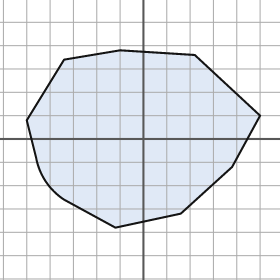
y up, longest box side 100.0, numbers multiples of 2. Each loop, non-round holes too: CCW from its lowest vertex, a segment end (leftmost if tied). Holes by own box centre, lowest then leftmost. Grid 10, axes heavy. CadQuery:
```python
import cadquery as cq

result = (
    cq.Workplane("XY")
    .moveTo(-12.0, -38.0)
    .lineTo(16.0, -32.0)
    .lineTo(38.0, -12.0)
    .lineTo(50.0, 10.0)
    .lineTo(22.0, 36.0)
    .lineTo(-10.0, 38.0)
    .lineTo(-34.0, 34.0)
    .lineTo(-50.0, 8.0)
    .lineTo(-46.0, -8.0)
    .threePointArc((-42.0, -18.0), (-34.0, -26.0))
    .close()
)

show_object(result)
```